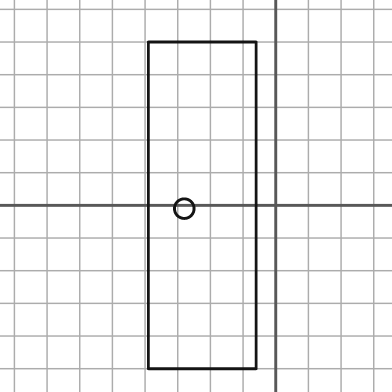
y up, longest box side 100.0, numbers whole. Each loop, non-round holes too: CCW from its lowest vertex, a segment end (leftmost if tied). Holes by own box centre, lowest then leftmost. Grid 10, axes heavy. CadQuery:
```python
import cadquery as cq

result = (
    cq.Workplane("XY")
    .moveTo(-39.0, -50.0)
    .lineTo(-6.0, -50.0)
    .lineTo(-6.0, 50.0)
    .lineTo(-39.0, 50.0)
    .close()
    .moveTo(-28.0, -1.0)
    .circle(3.0)
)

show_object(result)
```